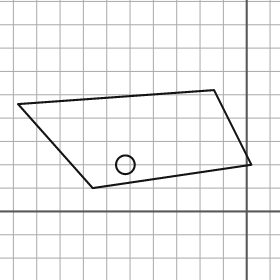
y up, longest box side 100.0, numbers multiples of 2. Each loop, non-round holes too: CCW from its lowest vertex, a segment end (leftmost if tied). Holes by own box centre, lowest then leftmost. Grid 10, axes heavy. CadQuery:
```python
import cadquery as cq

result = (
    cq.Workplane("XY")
    .moveTo(-66.0, 10.0)
    .lineTo(2.0, 20.0)
    .lineTo(-14.0, 52.0)
    .lineTo(-98.0, 46.0)
    .close()
    .moveTo(-52.0, 20.0)
    .circle(4.0)
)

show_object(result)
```